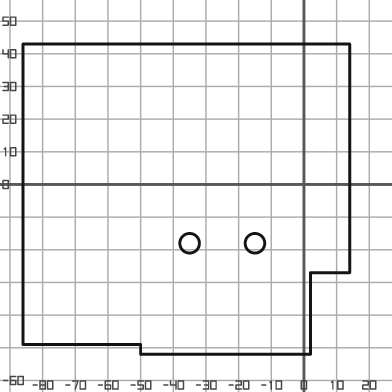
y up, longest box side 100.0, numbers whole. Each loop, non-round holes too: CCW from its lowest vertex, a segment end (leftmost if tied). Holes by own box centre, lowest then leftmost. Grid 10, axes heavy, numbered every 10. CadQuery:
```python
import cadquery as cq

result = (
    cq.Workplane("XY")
    .moveTo(-50.0, -52.0)
    .lineTo(2.0, -52.0)
    .lineTo(2.0, -27.0)
    .lineTo(14.0, -27.0)
    .lineTo(14.0, 43.0)
    .lineTo(-86.0, 43.0)
    .lineTo(-86.0, -49.0)
    .lineTo(-50.0, -49.0)
    .close()
    .moveTo(-35.0, -18.0)
    .circle(3.0)
    .moveTo(-15.0, -18.0)
    .circle(3.0)
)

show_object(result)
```